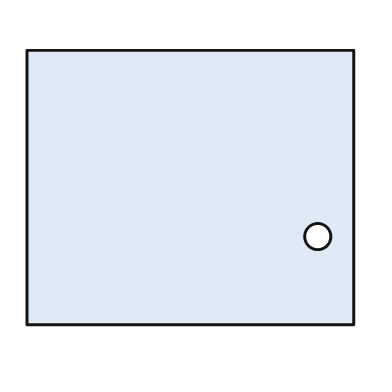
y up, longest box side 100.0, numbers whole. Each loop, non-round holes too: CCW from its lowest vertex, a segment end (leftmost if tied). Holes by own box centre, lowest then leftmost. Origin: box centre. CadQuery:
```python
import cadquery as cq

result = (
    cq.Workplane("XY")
    .moveTo(-50.0, -42.0)
    .lineTo(50.0, -42.0)
    .lineTo(50.0, 42.0)
    .lineTo(-50.0, 42.0)
    .close()
    .moveTo(39.0, -15.0)
    .circle(4.0)
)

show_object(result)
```